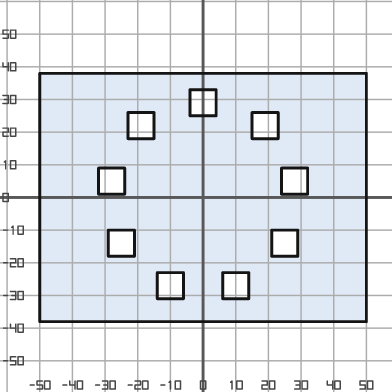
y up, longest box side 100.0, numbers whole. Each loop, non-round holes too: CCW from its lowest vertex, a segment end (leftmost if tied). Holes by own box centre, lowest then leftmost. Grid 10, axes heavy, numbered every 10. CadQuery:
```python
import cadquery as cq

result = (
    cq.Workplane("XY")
    .moveTo(-50.0, -38.0)
    .lineTo(50.0, -38.0)
    .lineTo(50.0, 38.0)
    .lineTo(-50.0, 38.0)
    .close()
    .moveTo(-14.0, -31.0)
    .lineTo(-6.0, -31.0)
    .lineTo(-6.0, -23.0)
    .lineTo(-14.0, -23.0)
    .close()
    .moveTo(6.0, -31.0)
    .lineTo(14.0, -31.0)
    .lineTo(14.0, -23.0)
    .lineTo(6.0, -23.0)
    .close()
    .moveTo(-29.0, -18.0)
    .lineTo(-21.0, -18.0)
    .lineTo(-21.0, -10.0)
    .lineTo(-29.0, -10.0)
    .close()
    .moveTo(21.0, -18.0)
    .lineTo(29.0, -18.0)
    .lineTo(29.0, -10.0)
    .lineTo(21.0, -10.0)
    .close()
    .moveTo(-32.0, 1.0)
    .lineTo(-24.0, 1.0)
    .lineTo(-24.0, 9.0)
    .lineTo(-32.0, 9.0)
    .close()
    .moveTo(24.0, 1.0)
    .lineTo(32.0, 1.0)
    .lineTo(32.0, 9.0)
    .lineTo(24.0, 9.0)
    .close()
    .moveTo(-23.0, 18.0)
    .lineTo(-15.0, 18.0)
    .lineTo(-15.0, 26.0)
    .lineTo(-23.0, 26.0)
    .close()
    .moveTo(15.0, 18.0)
    .lineTo(23.0, 18.0)
    .lineTo(23.0, 26.0)
    .lineTo(15.0, 26.0)
    .close()
    .moveTo(-4.0, 25.0)
    .lineTo(4.0, 25.0)
    .lineTo(4.0, 33.0)
    .lineTo(-4.0, 33.0)
    .close()
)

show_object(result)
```